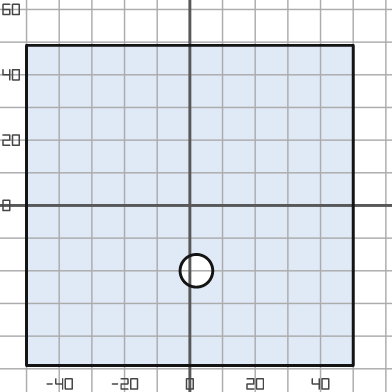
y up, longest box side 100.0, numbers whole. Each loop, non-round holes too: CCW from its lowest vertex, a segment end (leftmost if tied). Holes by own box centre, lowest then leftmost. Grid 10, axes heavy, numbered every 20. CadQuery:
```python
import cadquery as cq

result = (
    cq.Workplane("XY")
    .moveTo(-50.0, -49.0)
    .lineTo(50.0, -49.0)
    .lineTo(50.0, 49.0)
    .lineTo(-50.0, 49.0)
    .close()
    .moveTo(2.0, -20.0)
    .circle(5.0)
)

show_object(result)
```